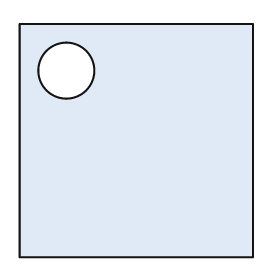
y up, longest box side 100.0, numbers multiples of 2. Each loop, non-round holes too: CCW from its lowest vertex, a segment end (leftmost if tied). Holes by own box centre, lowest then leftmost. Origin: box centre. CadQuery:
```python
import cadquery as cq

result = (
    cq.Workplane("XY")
    .moveTo(-50.0, -50.0)
    .lineTo(50.0, -50.0)
    .lineTo(50.0, 50.0)
    .lineTo(-50.0, 50.0)
    .close()
    .moveTo(-30.0, 30.0)
    .circle(12.0)
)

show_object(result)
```